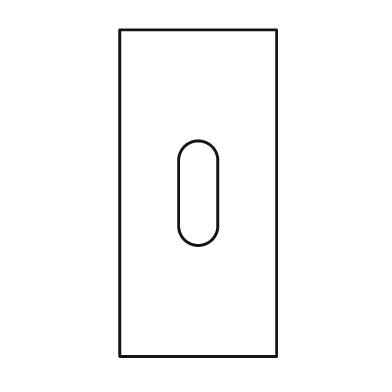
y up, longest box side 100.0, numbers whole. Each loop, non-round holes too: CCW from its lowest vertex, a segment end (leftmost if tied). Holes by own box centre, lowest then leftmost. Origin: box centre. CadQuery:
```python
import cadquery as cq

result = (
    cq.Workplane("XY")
    .moveTo(-24.0, -50.0)
    .lineTo(24.0, -50.0)
    .lineTo(24.0, 50.0)
    .lineTo(-24.0, 50.0)
    .close()
    .moveTo(-6.0, -10.0)
    .threePointArc((0.0, -16.0), (6.0, -10.0))
    .lineTo(6.0, 10.0)
    .threePointArc((0.0, 16.0), (-6.0, 10.0))
    .close()
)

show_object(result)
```